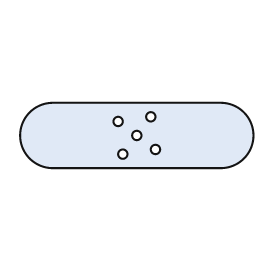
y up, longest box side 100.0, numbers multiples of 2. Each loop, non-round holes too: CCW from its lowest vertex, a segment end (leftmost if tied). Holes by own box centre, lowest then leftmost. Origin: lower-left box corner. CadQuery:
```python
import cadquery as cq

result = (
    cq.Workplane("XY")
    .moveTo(14.0, 0.0)
    .lineTo(86.0, 0.0)
    .threePointArc((100.0, 14.0), (86.0, 28.0))
    .lineTo(14.0, 28.0)
    .threePointArc((0.0, 14.0), (14.0, 0.0))
    .close()
    .moveTo(44.0, 6.0)
    .circle(2.0)
    .moveTo(58.0, 8.0)
    .circle(2.0)
    .moveTo(50.0, 14.0)
    .circle(2.0)
    .moveTo(42.0, 20.0)
    .circle(2.0)
    .moveTo(56.0, 22.0)
    .circle(2.0)
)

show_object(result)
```